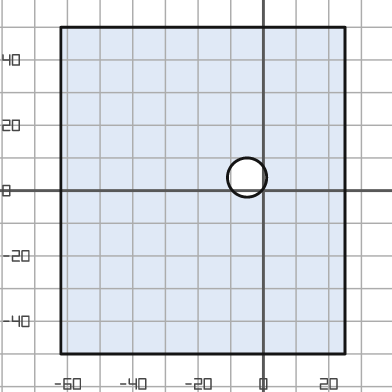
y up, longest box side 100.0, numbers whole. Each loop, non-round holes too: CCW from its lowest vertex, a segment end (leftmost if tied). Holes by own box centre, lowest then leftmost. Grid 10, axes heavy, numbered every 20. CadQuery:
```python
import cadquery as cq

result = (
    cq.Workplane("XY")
    .moveTo(-62.0, -50.0)
    .lineTo(25.0, -50.0)
    .lineTo(25.0, 50.0)
    .lineTo(-62.0, 50.0)
    .close()
    .moveTo(-5.0, 4.0)
    .circle(6.0)
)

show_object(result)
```